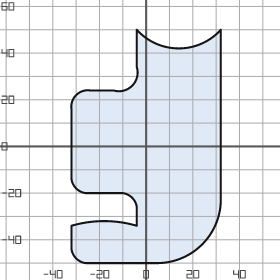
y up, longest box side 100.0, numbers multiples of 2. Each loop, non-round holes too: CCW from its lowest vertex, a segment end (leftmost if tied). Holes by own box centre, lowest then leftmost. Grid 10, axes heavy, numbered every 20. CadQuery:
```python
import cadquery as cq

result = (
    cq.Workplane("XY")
    .moveTo(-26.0, -50.0)
    .lineTo(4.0, -50.0)
    .threePointArc((24.0, -42.0), (32.0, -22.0))
    .lineTo(32.0, 50.0)
    .threePointArc((14.0, 42.0), (-4.0, 50.0))
    .lineTo(-4.0, 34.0)
    .threePointArc((-6.0, 26.0), (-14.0, 24.0))
    .lineTo(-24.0, 24.0)
    .threePointArc((-30.0, 22.0), (-32.0, 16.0))
    .lineTo(-32.0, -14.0)
    .threePointArc((-30.0, -18.0), (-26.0, -20.0))
    .lineTo(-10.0, -20.0)
    .threePointArc((-6.0, -22.0), (-4.0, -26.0))
    .lineTo(-4.0, -34.0)
    .threePointArc((-18.0, -32.0), (-32.0, -34.0))
    .lineTo(-32.0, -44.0)
    .threePointArc((-30.0, -48.0), (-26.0, -50.0))
    .close()
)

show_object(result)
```